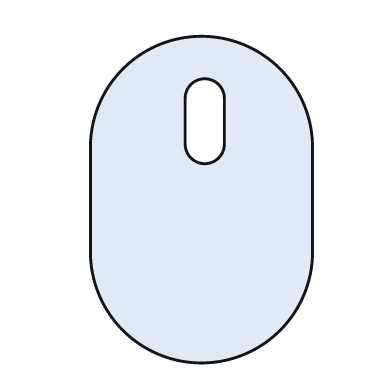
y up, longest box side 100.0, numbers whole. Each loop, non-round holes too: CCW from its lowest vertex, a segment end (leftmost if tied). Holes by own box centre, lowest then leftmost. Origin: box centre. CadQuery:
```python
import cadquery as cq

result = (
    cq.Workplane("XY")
    .moveTo(-34.0, -16.0)
    .threePointArc((0.0, -50.0), (34.0, -16.0))
    .lineTo(34.0, 16.0)
    .threePointArc((0.0, 50.0), (-34.0, 16.0))
    .close()
    .moveTo(-5.0, 17.0)
    .threePointArc((1.0, 11.0), (7.0, 17.0))
    .lineTo(7.0, 31.0)
    .threePointArc((1.0, 37.0), (-5.0, 31.0))
    .close()
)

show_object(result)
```